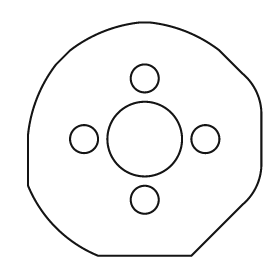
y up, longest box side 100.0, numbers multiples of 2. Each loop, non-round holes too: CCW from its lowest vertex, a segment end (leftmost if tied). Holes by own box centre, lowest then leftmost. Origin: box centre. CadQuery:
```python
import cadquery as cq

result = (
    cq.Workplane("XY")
    .moveTo(-20.0, -50.0)
    .lineTo(20.0, -50.0)
    .lineTo(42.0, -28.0)
    .threePointArc((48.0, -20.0), (50.0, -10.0))
    .lineTo(50.0, 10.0)
    .threePointArc((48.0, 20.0), (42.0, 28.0))
    .lineTo(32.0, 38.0)
    .threePointArc((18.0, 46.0), (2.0, 50.0))
    .lineTo(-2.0, 50.0)
    .threePointArc((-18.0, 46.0), (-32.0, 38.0))
    .lineTo(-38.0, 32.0)
    .threePointArc((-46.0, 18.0), (-50.0, 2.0))
    .lineTo(-50.0, -20.0)
    .threePointArc((-38.0, -38.0), (-20.0, -50.0))
    .close()
    .moveTo(0.0, -26.0)
    .circle(6.0)
    .moveTo(-26.0, 0.0)
    .circle(6.0)
    .moveTo(0.0, 0.0)
    .circle(16.0)
    .moveTo(26.0, 0.0)
    .circle(6.0)
    .moveTo(0.0, 26.0)
    .circle(6.0)
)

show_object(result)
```